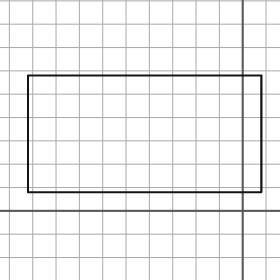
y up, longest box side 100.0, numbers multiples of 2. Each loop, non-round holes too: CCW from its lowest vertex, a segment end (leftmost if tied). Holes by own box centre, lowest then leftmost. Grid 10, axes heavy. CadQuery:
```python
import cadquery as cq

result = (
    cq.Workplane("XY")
    .moveTo(-92.0, 8.0)
    .lineTo(8.0, 8.0)
    .lineTo(8.0, 58.0)
    .lineTo(-92.0, 58.0)
    .close()
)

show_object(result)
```